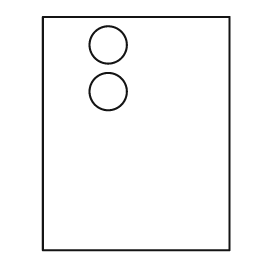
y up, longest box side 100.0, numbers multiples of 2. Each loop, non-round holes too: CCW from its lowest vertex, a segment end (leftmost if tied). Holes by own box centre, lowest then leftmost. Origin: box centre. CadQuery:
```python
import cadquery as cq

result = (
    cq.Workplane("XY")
    .moveTo(-40.0, -50.0)
    .lineTo(40.0, -50.0)
    .lineTo(40.0, 50.0)
    .lineTo(-40.0, 50.0)
    .close()
    .moveTo(-12.0, 18.0)
    .circle(8.0)
    .moveTo(-12.0, 38.0)
    .circle(8.0)
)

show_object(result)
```